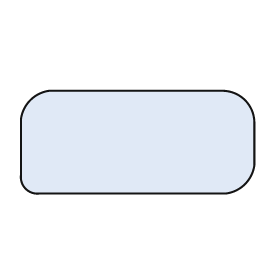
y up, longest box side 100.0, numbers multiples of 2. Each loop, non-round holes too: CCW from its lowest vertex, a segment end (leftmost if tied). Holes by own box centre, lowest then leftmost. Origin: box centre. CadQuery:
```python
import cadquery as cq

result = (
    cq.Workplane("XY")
    .moveTo(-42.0, -22.0)
    .lineTo(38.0, -22.0)
    .threePointArc((46.0, -18.0), (50.0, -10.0))
    .lineTo(50.0, 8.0)
    .threePointArc((46.0, 18.0), (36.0, 22.0))
    .lineTo(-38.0, 22.0)
    .threePointArc((-46.0, 18.0), (-50.0, 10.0))
    .lineTo(-50.0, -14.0)
    .threePointArc((-48.0, -20.0), (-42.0, -22.0))
    .close()
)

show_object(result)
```